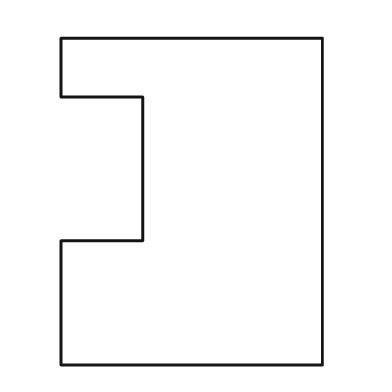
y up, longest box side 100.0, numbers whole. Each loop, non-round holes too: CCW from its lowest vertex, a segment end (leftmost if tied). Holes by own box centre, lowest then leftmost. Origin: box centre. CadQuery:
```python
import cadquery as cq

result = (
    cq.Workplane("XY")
    .moveTo(-40.0, -50.0)
    .lineTo(40.0, -50.0)
    .lineTo(40.0, 50.0)
    .lineTo(-40.0, 50.0)
    .lineTo(-40.0, 32.0)
    .lineTo(-15.0, 32.0)
    .lineTo(-15.0, -12.0)
    .lineTo(-40.0, -12.0)
    .close()
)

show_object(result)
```